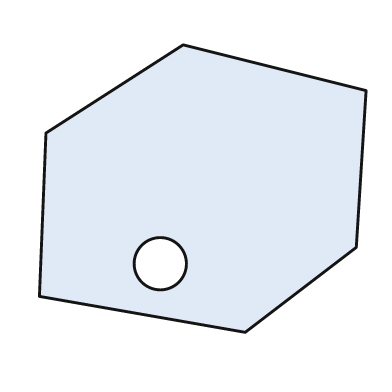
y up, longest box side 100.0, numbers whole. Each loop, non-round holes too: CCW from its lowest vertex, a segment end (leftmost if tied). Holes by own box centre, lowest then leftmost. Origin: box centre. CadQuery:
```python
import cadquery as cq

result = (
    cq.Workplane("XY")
    .moveTo(13.0, -44.0)
    .lineTo(47.0, -18.0)
    .lineTo(50.0, 30.0)
    .lineTo(-6.0, 44.0)
    .lineTo(-48.0, 17.0)
    .lineTo(-50.0, -33.0)
    .close()
    .moveTo(-13.0, -23.0)
    .circle(8.0)
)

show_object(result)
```